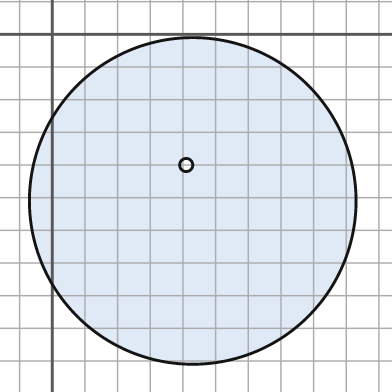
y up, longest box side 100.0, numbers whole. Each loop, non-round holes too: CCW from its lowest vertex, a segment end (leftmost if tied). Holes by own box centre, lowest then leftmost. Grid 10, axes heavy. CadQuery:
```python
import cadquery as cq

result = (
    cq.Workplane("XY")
    .moveTo(43.0, -51.0)
    .circle(50.0)
    .moveTo(41.0, -40.0)
    .circle(2.0)
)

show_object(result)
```